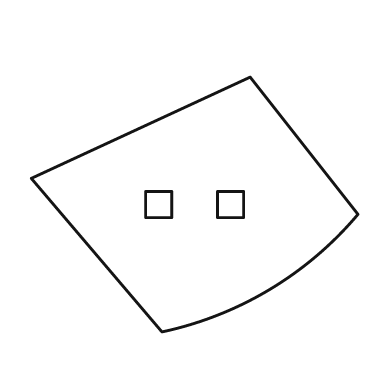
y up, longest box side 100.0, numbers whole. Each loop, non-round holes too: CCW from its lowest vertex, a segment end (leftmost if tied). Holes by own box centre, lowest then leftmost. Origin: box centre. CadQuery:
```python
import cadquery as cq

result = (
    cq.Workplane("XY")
    .moveTo(-10.0, -39.0)
    .threePointArc((23.0, -26.0), (50.0, -3.0))
    .lineTo(17.0, 39.0)
    .lineTo(-50.0, 8.0)
    .close()
    .moveTo(-15.0, -4.0)
    .lineTo(-7.0, -4.0)
    .lineTo(-7.0, 4.0)
    .lineTo(-15.0, 4.0)
    .close()
    .moveTo(7.0, -4.0)
    .lineTo(15.0, -4.0)
    .lineTo(15.0, 4.0)
    .lineTo(7.0, 4.0)
    .close()
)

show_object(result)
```